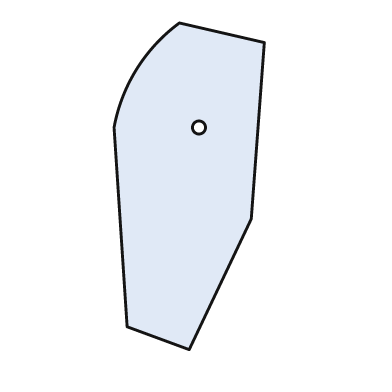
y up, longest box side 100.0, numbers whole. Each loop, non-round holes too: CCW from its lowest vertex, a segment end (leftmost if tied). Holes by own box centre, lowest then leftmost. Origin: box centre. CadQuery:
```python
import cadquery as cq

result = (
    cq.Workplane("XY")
    .moveTo(0.0, -50.0)
    .lineTo(19.0, -10.0)
    .lineTo(23.0, 44.0)
    .lineTo(-3.0, 50.0)
    .threePointArc((-16.0, 36.0), (-23.0, 18.0))
    .lineTo(-19.0, -43.0)
    .close()
    .moveTo(3.0, 18.0)
    .circle(2.0)
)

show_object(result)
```